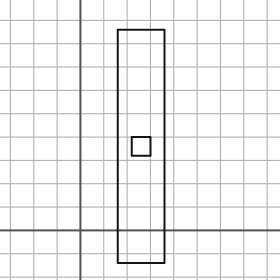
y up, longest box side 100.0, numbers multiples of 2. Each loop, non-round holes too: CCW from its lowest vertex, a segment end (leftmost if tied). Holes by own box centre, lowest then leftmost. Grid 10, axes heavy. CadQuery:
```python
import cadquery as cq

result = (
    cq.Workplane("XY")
    .moveTo(16.0, -14.0)
    .lineTo(36.0, -14.0)
    .lineTo(36.0, 86.0)
    .lineTo(16.0, 86.0)
    .close()
    .moveTo(22.0, 32.0)
    .lineTo(30.0, 32.0)
    .lineTo(30.0, 40.0)
    .lineTo(22.0, 40.0)
    .close()
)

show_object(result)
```